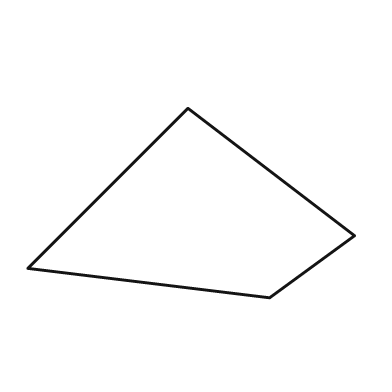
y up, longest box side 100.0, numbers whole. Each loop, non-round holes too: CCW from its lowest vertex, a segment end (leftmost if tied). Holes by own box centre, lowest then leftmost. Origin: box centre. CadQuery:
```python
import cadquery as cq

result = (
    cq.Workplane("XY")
    .moveTo(24.0, -29.0)
    .lineTo(50.0, -10.0)
    .lineTo(-1.0, 29.0)
    .lineTo(-50.0, -20.0)
    .close()
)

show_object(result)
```